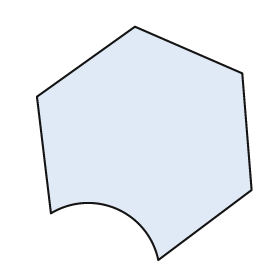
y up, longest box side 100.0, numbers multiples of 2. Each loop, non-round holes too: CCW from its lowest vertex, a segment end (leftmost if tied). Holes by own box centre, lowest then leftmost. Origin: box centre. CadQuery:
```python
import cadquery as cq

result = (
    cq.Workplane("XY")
    .moveTo(6.0, -50.0)
    .lineTo(46.0, -20.0)
    .lineTo(42.0, 30.0)
    .lineTo(-4.0, 50.0)
    .lineTo(-46.0, 20.0)
    .lineTo(-40.0, -30.0)
    .threePointArc((-12.0, -28.0), (6.0, -50.0))
    .close()
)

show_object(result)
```